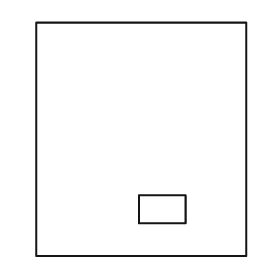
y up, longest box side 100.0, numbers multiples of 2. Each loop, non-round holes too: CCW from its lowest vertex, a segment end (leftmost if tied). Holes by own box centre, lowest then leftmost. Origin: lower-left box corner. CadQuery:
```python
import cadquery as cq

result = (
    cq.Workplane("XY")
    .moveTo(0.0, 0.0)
    .lineTo(90.0, 0.0)
    .lineTo(90.0, 100.0)
    .lineTo(0.0, 100.0)
    .close()
    .moveTo(44.0, 14.0)
    .lineTo(64.0, 14.0)
    .lineTo(64.0, 26.0)
    .lineTo(44.0, 26.0)
    .close()
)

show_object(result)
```